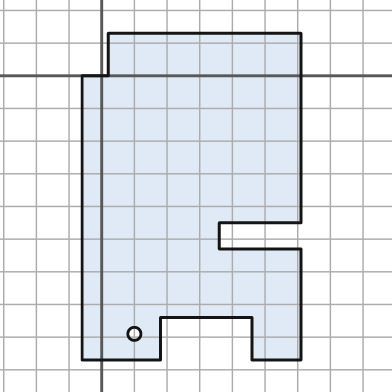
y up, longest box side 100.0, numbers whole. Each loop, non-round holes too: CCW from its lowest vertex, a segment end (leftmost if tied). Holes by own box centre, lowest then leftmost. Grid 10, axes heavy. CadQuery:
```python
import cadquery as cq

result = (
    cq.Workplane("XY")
    .moveTo(-6.0, -87.0)
    .lineTo(18.0, -87.0)
    .lineTo(18.0, -74.0)
    .lineTo(46.0, -74.0)
    .lineTo(46.0, -87.0)
    .lineTo(61.0, -87.0)
    .lineTo(61.0, -53.0)
    .lineTo(36.0, -53.0)
    .lineTo(36.0, -45.0)
    .lineTo(61.0, -45.0)
    .lineTo(61.0, 13.0)
    .lineTo(2.0, 13.0)
    .lineTo(2.0, 0.0)
    .lineTo(-6.0, 0.0)
    .close()
    .moveTo(10.0, -79.0)
    .circle(2.0)
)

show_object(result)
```